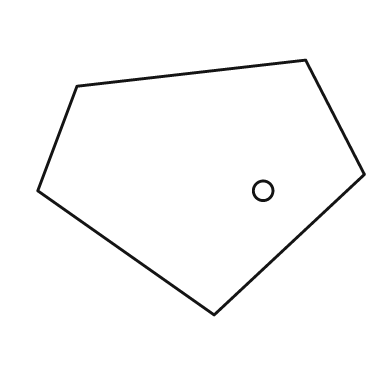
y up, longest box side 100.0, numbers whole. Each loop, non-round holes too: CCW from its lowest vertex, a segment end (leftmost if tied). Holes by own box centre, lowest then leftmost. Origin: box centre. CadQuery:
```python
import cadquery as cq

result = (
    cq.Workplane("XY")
    .moveTo(4.0, -39.0)
    .lineTo(50.0, 4.0)
    .lineTo(32.0, 39.0)
    .lineTo(-38.0, 31.0)
    .lineTo(-50.0, -1.0)
    .close()
    .moveTo(19.0, -1.0)
    .circle(3.0)
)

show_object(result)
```